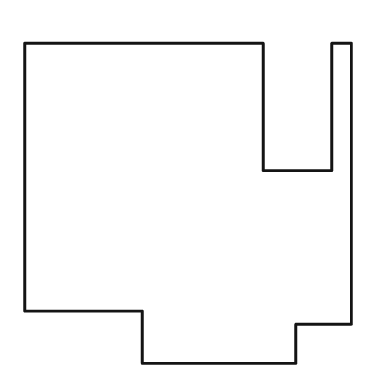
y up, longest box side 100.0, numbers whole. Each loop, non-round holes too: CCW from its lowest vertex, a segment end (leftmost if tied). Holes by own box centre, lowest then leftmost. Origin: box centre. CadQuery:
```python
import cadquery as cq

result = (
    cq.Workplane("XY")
    .moveTo(-14.0, -49.0)
    .lineTo(33.0, -49.0)
    .lineTo(33.0, -37.0)
    .lineTo(50.0, -37.0)
    .lineTo(50.0, 49.0)
    .lineTo(44.0, 49.0)
    .lineTo(44.0, 10.0)
    .lineTo(23.0, 10.0)
    .lineTo(23.0, 49.0)
    .lineTo(-50.0, 49.0)
    .lineTo(-50.0, -33.0)
    .lineTo(-14.0, -33.0)
    .close()
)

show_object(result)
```